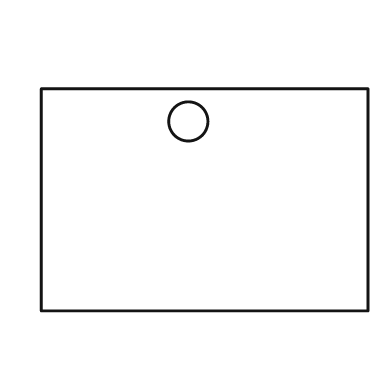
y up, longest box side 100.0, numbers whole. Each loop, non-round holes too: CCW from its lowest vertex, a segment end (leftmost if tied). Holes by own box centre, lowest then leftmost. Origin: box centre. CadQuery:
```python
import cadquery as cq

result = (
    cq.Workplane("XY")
    .moveTo(-50.0, -34.0)
    .lineTo(50.0, -34.0)
    .lineTo(50.0, 34.0)
    .lineTo(-50.0, 34.0)
    .close()
    .moveTo(-5.0, 24.0)
    .circle(6.0)
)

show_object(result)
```